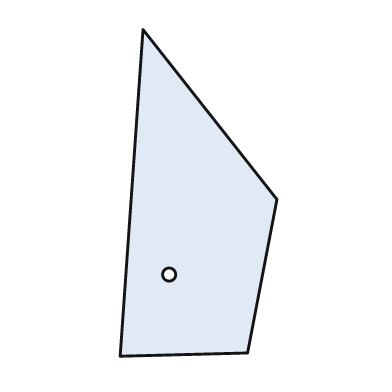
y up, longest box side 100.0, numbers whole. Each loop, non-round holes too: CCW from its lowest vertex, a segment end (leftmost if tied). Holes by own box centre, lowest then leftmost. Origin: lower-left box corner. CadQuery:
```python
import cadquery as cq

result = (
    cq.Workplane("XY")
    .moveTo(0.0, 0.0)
    .lineTo(39.0, 1.0)
    .lineTo(48.0, 48.0)
    .lineTo(7.0, 100.0)
    .close()
    .moveTo(15.0, 25.0)
    .circle(2.0)
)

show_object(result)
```